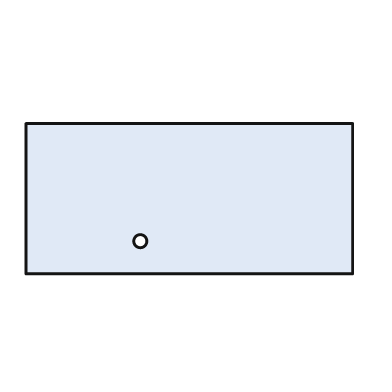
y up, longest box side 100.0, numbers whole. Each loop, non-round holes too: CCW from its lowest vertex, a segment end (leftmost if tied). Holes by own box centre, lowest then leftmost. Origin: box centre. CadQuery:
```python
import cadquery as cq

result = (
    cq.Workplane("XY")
    .moveTo(-50.0, -23.0)
    .lineTo(50.0, -23.0)
    .lineTo(50.0, 23.0)
    .lineTo(-50.0, 23.0)
    .close()
    .moveTo(-15.0, -13.0)
    .circle(2.0)
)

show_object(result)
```